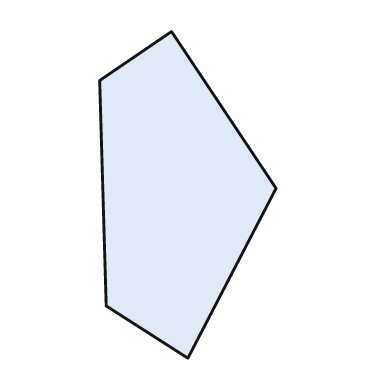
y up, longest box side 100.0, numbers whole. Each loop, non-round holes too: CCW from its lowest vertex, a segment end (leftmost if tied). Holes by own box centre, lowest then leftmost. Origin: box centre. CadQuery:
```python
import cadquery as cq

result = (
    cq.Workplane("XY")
    .moveTo(0.0, -50.0)
    .lineTo(27.0, 2.0)
    .lineTo(-5.0, 50.0)
    .lineTo(-27.0, 35.0)
    .lineTo(-25.0, -34.0)
    .close()
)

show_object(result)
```